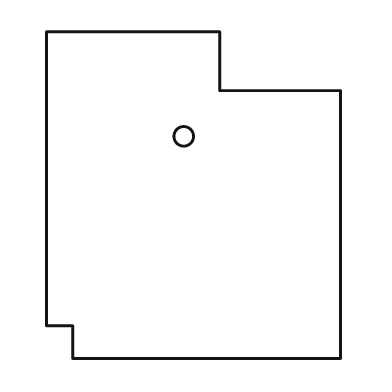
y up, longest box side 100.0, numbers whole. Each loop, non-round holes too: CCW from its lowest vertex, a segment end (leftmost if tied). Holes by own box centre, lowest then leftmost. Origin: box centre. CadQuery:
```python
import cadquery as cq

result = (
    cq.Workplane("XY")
    .moveTo(-37.0, -50.0)
    .lineTo(45.0, -50.0)
    .lineTo(45.0, 32.0)
    .lineTo(8.0, 32.0)
    .lineTo(8.0, 50.0)
    .lineTo(-45.0, 50.0)
    .lineTo(-45.0, -40.0)
    .lineTo(-37.0, -40.0)
    .close()
    .moveTo(-3.0, 18.0)
    .circle(3.0)
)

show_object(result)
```